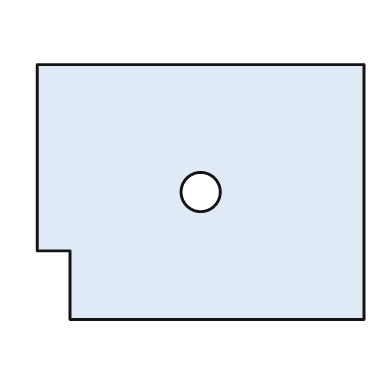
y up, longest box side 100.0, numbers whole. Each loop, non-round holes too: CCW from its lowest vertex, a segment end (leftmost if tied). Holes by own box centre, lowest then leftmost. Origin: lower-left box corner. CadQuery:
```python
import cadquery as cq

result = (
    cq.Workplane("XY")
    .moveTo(10.0, 0.0)
    .lineTo(100.0, 0.0)
    .lineTo(100.0, 78.0)
    .lineTo(0.0, 78.0)
    .lineTo(0.0, 21.0)
    .lineTo(10.0, 21.0)
    .close()
    .moveTo(50.0, 39.0)
    .circle(6.0)
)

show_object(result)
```